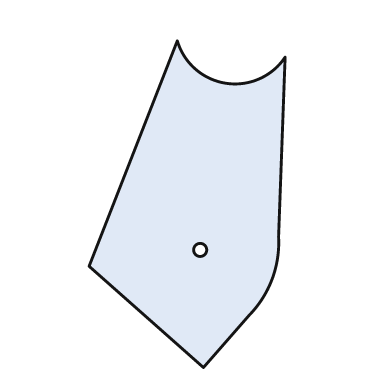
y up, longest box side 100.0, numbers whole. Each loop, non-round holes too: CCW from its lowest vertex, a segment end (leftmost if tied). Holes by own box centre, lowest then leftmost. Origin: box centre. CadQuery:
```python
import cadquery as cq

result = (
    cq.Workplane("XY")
    .moveTo(5.0, -50.0)
    .lineTo(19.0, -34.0)
    .threePointArc((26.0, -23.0), (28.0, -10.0))
    .lineTo(30.0, 45.0)
    .threePointArc((12.0, 37.0), (-3.0, 50.0))
    .lineTo(-30.0, -19.0)
    .close()
    .moveTo(4.0, -14.0)
    .circle(2.0)
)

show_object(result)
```